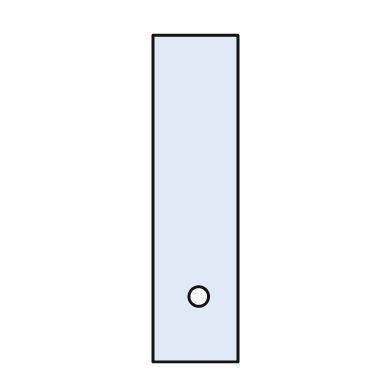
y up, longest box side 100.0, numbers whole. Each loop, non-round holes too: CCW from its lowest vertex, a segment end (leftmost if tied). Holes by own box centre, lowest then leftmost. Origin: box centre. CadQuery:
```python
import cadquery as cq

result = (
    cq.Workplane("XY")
    .moveTo(-13.0, -50.0)
    .lineTo(13.0, -50.0)
    .lineTo(13.0, 50.0)
    .lineTo(-13.0, 50.0)
    .close()
    .moveTo(1.0, -30.0)
    .circle(3.0)
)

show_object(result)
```